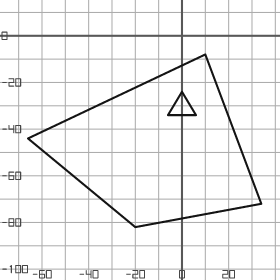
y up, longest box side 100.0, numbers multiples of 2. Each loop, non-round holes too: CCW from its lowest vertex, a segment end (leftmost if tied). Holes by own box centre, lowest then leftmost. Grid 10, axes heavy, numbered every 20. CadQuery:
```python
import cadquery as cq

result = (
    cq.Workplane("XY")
    .moveTo(-20.0, -82.0)
    .lineTo(34.0, -72.0)
    .lineTo(10.0, -8.0)
    .lineTo(-66.0, -44.0)
    .close()
    .moveTo(-6.0, -34.0)
    .lineTo(6.0, -34.0)
    .lineTo(0.0, -24.0)
    .close()
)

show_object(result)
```